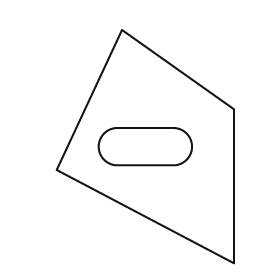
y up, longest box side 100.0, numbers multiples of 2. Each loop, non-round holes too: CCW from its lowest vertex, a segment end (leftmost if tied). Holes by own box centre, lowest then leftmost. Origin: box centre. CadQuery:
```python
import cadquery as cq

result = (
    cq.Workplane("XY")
    .moveTo(38.0, -50.0)
    .lineTo(38.0, 16.0)
    .lineTo(-10.0, 50.0)
    .lineTo(-38.0, -10.0)
    .close()
    .moveTo(-12.0, -8.0)
    .lineTo(12.0, -8.0)
    .threePointArc((20.0, 0.0), (12.0, 8.0))
    .lineTo(-12.0, 8.0)
    .threePointArc((-20.0, 0.0), (-12.0, -8.0))
    .close()
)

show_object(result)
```